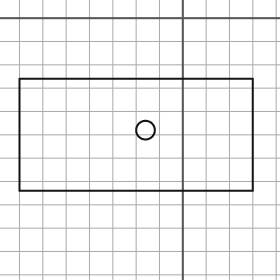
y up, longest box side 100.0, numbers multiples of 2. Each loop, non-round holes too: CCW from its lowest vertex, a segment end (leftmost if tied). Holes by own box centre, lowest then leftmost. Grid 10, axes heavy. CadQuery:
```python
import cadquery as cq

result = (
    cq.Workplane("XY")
    .moveTo(-70.0, -74.0)
    .lineTo(30.0, -74.0)
    .lineTo(30.0, -26.0)
    .lineTo(-70.0, -26.0)
    .close()
    .moveTo(-16.0, -48.0)
    .circle(4.0)
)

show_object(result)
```